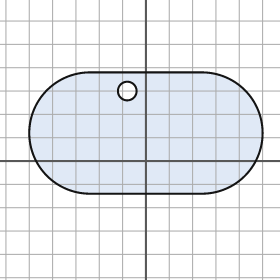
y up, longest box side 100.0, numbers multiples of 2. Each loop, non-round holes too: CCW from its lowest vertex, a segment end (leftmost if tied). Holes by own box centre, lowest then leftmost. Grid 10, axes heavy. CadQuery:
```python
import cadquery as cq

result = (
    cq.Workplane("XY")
    .moveTo(-24.0, -14.0)
    .lineTo(24.0, -14.0)
    .threePointArc((50.0, 12.0), (24.0, 38.0))
    .lineTo(-24.0, 38.0)
    .threePointArc((-50.0, 12.0), (-24.0, -14.0))
    .close()
    .moveTo(-8.0, 30.0)
    .circle(4.0)
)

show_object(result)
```